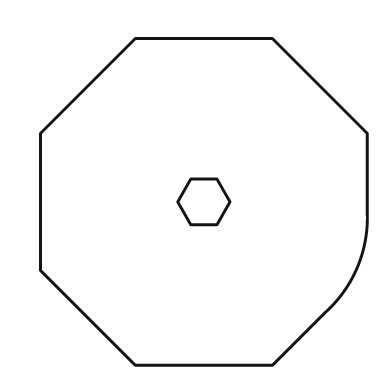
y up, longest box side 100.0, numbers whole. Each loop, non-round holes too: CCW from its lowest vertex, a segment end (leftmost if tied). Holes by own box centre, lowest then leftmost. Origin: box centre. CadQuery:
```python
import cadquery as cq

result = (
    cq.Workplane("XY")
    .moveTo(-21.0, -50.0)
    .lineTo(21.0, -50.0)
    .lineTo(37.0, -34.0)
    .threePointArc((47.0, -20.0), (50.0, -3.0))
    .lineTo(50.0, 21.0)
    .lineTo(21.0, 50.0)
    .lineTo(-21.0, 50.0)
    .lineTo(-50.0, 21.0)
    .lineTo(-50.0, -21.0)
    .close()
    .moveTo(-4.0, -7.0)
    .lineTo(4.0, -7.0)
    .lineTo(8.0, 0.0)
    .lineTo(4.0, 7.0)
    .lineTo(-4.0, 7.0)
    .lineTo(-8.0, 0.0)
    .close()
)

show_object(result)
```